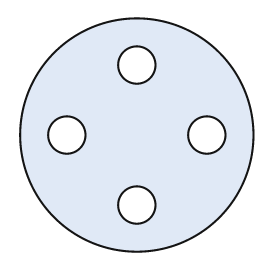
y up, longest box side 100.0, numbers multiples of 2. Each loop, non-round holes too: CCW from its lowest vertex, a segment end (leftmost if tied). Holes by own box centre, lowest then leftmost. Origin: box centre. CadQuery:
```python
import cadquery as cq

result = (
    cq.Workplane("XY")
    .moveTo(0.0, 0.0)
    .circle(50.0)
    .moveTo(0.0, -30.0)
    .circle(8.0)
    .moveTo(-30.0, 0.0)
    .circle(8.0)
    .moveTo(30.0, 0.0)
    .circle(8.0)
    .moveTo(0.0, 30.0)
    .circle(8.0)
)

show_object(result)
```